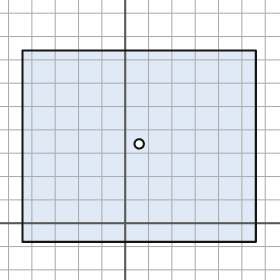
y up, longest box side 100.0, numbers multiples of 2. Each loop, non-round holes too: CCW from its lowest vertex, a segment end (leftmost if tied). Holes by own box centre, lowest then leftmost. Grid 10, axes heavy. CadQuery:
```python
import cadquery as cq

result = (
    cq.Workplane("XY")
    .moveTo(-44.0, -8.0)
    .lineTo(56.0, -8.0)
    .lineTo(56.0, 74.0)
    .lineTo(-44.0, 74.0)
    .close()
    .moveTo(6.0, 34.0)
    .circle(2.0)
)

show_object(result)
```